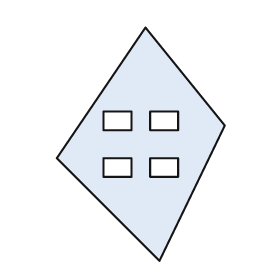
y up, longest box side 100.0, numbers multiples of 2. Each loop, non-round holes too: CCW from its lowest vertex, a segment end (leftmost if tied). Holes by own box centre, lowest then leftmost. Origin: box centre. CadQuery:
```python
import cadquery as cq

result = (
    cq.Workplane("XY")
    .moveTo(8.0, -50.0)
    .lineTo(36.0, 8.0)
    .lineTo(2.0, 50.0)
    .lineTo(-36.0, -6.0)
    .close()
    .moveTo(-16.0, -14.0)
    .lineTo(-4.0, -14.0)
    .lineTo(-4.0, -6.0)
    .lineTo(-16.0, -6.0)
    .close()
    .moveTo(4.0, -14.0)
    .lineTo(16.0, -14.0)
    .lineTo(16.0, -6.0)
    .lineTo(4.0, -6.0)
    .close()
    .moveTo(-16.0, 6.0)
    .lineTo(-4.0, 6.0)
    .lineTo(-4.0, 14.0)
    .lineTo(-16.0, 14.0)
    .close()
    .moveTo(4.0, 6.0)
    .lineTo(16.0, 6.0)
    .lineTo(16.0, 14.0)
    .lineTo(4.0, 14.0)
    .close()
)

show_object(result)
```